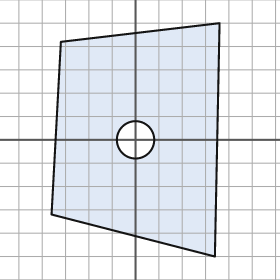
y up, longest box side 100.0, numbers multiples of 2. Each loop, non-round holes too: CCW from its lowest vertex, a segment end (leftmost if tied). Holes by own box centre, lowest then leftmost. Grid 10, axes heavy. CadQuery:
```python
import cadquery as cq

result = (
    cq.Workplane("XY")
    .moveTo(34.0, -50.0)
    .lineTo(36.0, 50.0)
    .lineTo(-32.0, 42.0)
    .lineTo(-36.0, -32.0)
    .close()
    .moveTo(0.0, 0.0)
    .circle(8.0)
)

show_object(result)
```